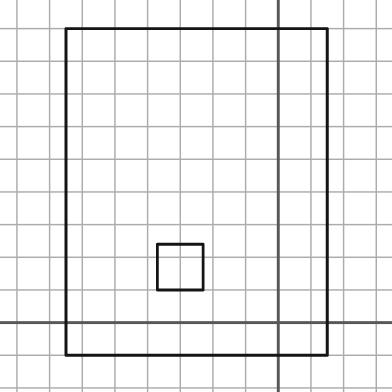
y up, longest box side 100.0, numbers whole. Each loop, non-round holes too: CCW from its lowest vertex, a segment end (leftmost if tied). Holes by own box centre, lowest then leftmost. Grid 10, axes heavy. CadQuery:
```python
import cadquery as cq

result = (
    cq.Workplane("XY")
    .moveTo(-65.0, -10.0)
    .lineTo(15.0, -10.0)
    .lineTo(15.0, 90.0)
    .lineTo(-65.0, 90.0)
    .close()
    .moveTo(-37.0, 10.0)
    .lineTo(-23.0, 10.0)
    .lineTo(-23.0, 24.0)
    .lineTo(-37.0, 24.0)
    .close()
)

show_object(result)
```